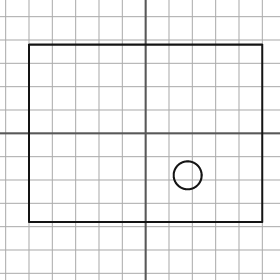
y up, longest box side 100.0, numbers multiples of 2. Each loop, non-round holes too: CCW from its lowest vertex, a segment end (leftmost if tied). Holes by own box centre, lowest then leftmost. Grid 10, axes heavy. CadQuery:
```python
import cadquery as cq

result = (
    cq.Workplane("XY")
    .moveTo(-50.0, -38.0)
    .lineTo(50.0, -38.0)
    .lineTo(50.0, 38.0)
    .lineTo(-50.0, 38.0)
    .close()
    .moveTo(18.0, -18.0)
    .circle(6.0)
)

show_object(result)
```